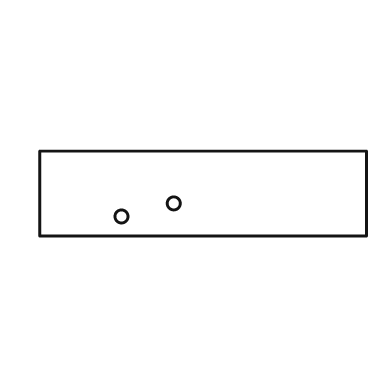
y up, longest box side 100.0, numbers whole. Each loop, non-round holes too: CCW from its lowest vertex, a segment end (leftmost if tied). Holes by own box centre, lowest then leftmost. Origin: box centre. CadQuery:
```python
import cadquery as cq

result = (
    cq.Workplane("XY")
    .moveTo(-50.0, -13.0)
    .lineTo(50.0, -13.0)
    .lineTo(50.0, 13.0)
    .lineTo(-50.0, 13.0)
    .close()
    .moveTo(-25.0, -7.0)
    .circle(2.0)
    .moveTo(-9.0, -3.0)
    .circle(2.0)
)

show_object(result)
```